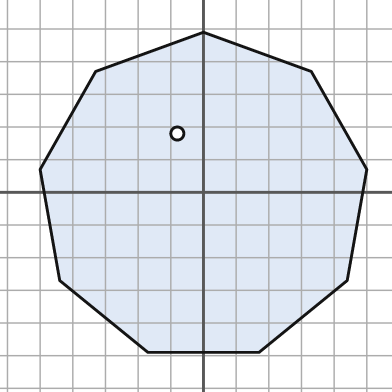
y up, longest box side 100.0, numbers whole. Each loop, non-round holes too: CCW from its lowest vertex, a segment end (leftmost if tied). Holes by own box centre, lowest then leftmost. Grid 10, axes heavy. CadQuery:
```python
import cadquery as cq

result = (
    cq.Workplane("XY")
    .moveTo(-17.0, -49.0)
    .lineTo(17.0, -49.0)
    .lineTo(44.0, -27.0)
    .lineTo(50.0, 7.0)
    .lineTo(33.0, 37.0)
    .lineTo(0.0, 49.0)
    .lineTo(-33.0, 37.0)
    .lineTo(-50.0, 7.0)
    .lineTo(-44.0, -27.0)
    .close()
    .moveTo(-8.0, 18.0)
    .circle(2.0)
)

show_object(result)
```